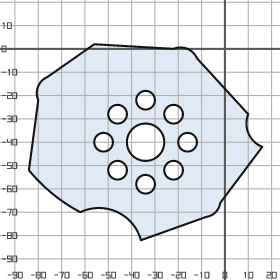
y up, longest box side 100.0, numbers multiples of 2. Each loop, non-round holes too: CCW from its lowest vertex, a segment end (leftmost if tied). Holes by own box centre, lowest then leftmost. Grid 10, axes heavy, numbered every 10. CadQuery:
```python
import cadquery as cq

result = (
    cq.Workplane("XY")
    .moveTo(-36.0, -82.0)
    .lineTo(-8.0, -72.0)
    .threePointArc((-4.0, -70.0), (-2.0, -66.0))
    .lineTo(16.0, -42.0)
    .threePointArc((10.0, -36.0), (10.0, -28.0))
    .lineTo(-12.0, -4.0)
    .threePointArc((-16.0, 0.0), (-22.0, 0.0))
    .lineTo(-56.0, 2.0)
    .lineTo(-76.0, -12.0)
    .threePointArc((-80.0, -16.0), (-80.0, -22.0))
    .lineTo(-84.0, -52.0)
    .threePointArc((-74.0, -62.0), (-62.0, -70.0))
    .threePointArc((-46.0, -70.0), (-36.0, -82.0))
    .close()
    .moveTo(-34.0, -58.0)
    .circle(4.0)
    .moveTo(-46.0, -52.0)
    .circle(4.0)
    .moveTo(-22.0, -52.0)
    .circle(4.0)
    .moveTo(-52.0, -40.0)
    .circle(4.0)
    .moveTo(-34.0, -40.0)
    .circle(8.0)
    .moveTo(-16.0, -40.0)
    .circle(4.0)
    .moveTo(-46.0, -28.0)
    .circle(4.0)
    .moveTo(-22.0, -28.0)
    .circle(4.0)
    .moveTo(-34.0, -22.0)
    .circle(4.0)
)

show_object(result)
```